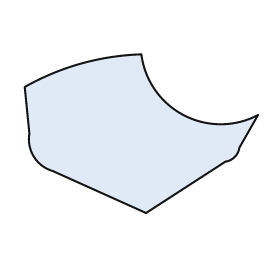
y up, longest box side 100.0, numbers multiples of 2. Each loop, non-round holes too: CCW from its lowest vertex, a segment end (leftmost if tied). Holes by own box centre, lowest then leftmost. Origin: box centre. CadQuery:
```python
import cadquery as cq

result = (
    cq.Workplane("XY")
    .moveTo(2.0, -34.0)
    .lineTo(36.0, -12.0)
    .threePointArc((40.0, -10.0), (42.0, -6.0))
    .lineTo(50.0, 8.0)
    .threePointArc((18.0, 8.0), (0.0, 34.0))
    .threePointArc((-26.0, 30.0), (-50.0, 20.0))
    .lineTo(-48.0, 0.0)
    .threePointArc((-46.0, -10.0), (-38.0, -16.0))
    .close()
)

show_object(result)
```